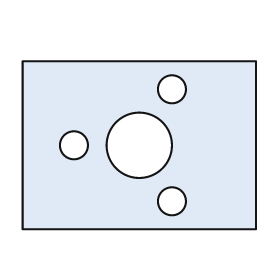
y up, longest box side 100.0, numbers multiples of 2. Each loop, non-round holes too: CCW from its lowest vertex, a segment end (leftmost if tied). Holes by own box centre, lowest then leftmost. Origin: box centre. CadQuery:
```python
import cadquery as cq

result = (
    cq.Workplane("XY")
    .moveTo(-50.0, -36.0)
    .lineTo(50.0, -36.0)
    .lineTo(50.0, 36.0)
    .lineTo(-50.0, 36.0)
    .close()
    .moveTo(14.0, -24.0)
    .circle(6.0)
    .moveTo(-28.0, 0.0)
    .circle(6.0)
    .moveTo(0.0, 0.0)
    .circle(14.0)
    .moveTo(14.0, 24.0)
    .circle(6.0)
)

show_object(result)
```